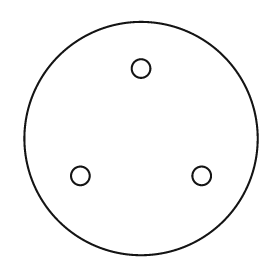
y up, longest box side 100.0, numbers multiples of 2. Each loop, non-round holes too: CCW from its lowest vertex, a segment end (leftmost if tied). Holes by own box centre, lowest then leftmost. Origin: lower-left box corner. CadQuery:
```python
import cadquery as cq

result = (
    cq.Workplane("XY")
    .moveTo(50.0, 50.0)
    .circle(50.0)
    .moveTo(24.0, 34.0)
    .circle(4.0)
    .moveTo(76.0, 34.0)
    .circle(4.0)
    .moveTo(50.0, 80.0)
    .circle(4.0)
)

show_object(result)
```